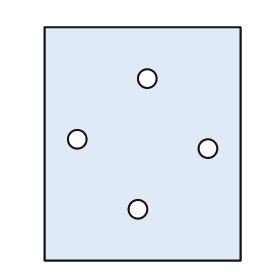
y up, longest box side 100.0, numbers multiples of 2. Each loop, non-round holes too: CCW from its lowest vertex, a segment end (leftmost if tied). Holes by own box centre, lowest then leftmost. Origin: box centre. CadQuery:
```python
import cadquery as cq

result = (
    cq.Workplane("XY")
    .moveTo(-42.0, -50.0)
    .lineTo(42.0, -50.0)
    .lineTo(42.0, 50.0)
    .lineTo(-42.0, 50.0)
    .close()
    .moveTo(-2.0, -28.0)
    .circle(4.0)
    .moveTo(28.0, -2.0)
    .circle(4.0)
    .moveTo(-28.0, 2.0)
    .circle(4.0)
    .moveTo(2.0, 28.0)
    .circle(4.0)
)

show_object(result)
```